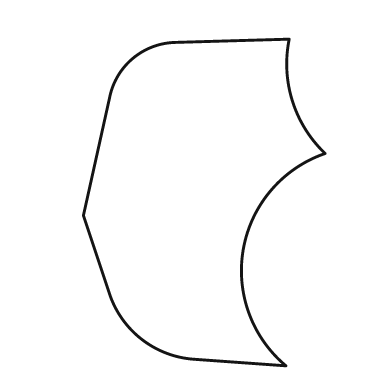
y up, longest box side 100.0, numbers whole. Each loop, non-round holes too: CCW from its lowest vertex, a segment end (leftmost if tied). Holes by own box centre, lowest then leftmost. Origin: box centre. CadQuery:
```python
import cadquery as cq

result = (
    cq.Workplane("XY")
    .moveTo(25.0, -50.0)
    .threePointArc((12.0, -14.0), (37.0, 15.0))
    .threePointArc((27.0, 31.0), (26.0, 50.0))
    .lineTo(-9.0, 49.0)
    .threePointArc((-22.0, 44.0), (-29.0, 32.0))
    .lineTo(-37.0, -4.0)
    .lineTo(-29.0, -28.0)
    .threePointArc((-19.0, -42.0), (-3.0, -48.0))
    .close()
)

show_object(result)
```